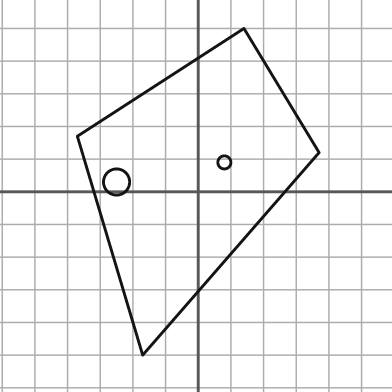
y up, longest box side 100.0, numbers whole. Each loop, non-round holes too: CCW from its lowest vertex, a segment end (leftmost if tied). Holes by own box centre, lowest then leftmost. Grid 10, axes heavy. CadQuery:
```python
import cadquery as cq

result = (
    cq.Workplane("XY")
    .moveTo(-17.0, -50.0)
    .lineTo(37.0, 12.0)
    .lineTo(14.0, 50.0)
    .lineTo(-37.0, 17.0)
    .close()
    .moveTo(-25.0, 3.0)
    .circle(4.0)
    .moveTo(8.0, 9.0)
    .circle(2.0)
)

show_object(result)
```